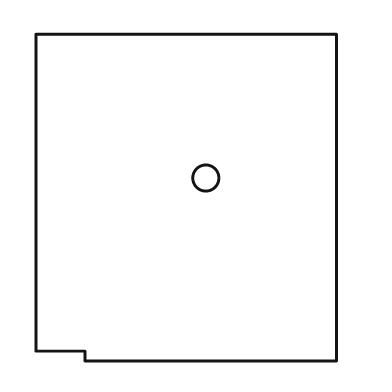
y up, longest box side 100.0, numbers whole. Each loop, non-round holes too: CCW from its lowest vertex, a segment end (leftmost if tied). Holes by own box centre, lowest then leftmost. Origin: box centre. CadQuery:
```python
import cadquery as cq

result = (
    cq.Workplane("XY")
    .moveTo(-31.0, -50.0)
    .lineTo(46.0, -50.0)
    .lineTo(46.0, 50.0)
    .lineTo(-46.0, 50.0)
    .lineTo(-46.0, -47.0)
    .lineTo(-31.0, -47.0)
    .close()
    .moveTo(6.0, 6.0)
    .circle(4.0)
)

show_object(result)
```